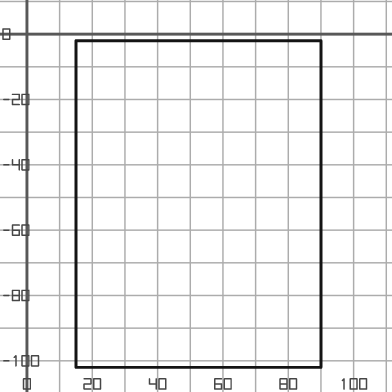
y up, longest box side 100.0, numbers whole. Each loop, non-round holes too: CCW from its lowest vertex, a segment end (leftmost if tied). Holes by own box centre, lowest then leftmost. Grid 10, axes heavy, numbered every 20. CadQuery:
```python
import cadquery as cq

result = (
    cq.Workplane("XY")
    .moveTo(15.0, -102.0)
    .lineTo(90.0, -102.0)
    .lineTo(90.0, -2.0)
    .lineTo(15.0, -2.0)
    .close()
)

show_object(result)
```